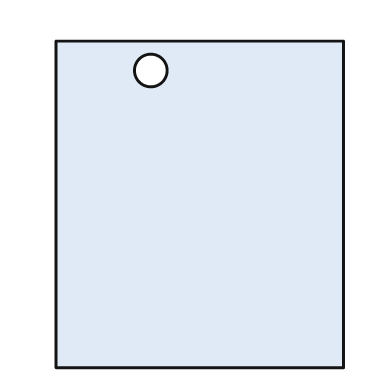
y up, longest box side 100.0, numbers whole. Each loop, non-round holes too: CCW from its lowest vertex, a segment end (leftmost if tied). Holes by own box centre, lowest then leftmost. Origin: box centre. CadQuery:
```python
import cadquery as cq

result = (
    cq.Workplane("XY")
    .moveTo(-44.0, -50.0)
    .lineTo(44.0, -50.0)
    .lineTo(44.0, 50.0)
    .lineTo(-44.0, 50.0)
    .close()
    .moveTo(-15.0, 41.0)
    .circle(5.0)
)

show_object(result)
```